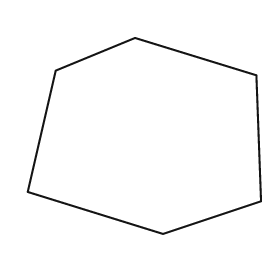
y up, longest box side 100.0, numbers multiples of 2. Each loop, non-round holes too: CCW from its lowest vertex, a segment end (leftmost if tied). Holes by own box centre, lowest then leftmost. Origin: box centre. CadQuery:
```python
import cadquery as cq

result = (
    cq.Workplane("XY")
    .moveTo(8.0, -42.0)
    .lineTo(50.0, -28.0)
    .lineTo(48.0, 26.0)
    .lineTo(-4.0, 42.0)
    .lineTo(-38.0, 28.0)
    .lineTo(-50.0, -24.0)
    .close()
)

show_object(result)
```